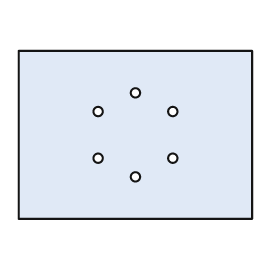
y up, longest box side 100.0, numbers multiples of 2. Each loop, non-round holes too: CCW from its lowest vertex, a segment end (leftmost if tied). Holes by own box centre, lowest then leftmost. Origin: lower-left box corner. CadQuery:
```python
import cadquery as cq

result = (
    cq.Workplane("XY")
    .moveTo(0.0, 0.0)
    .lineTo(100.0, 0.0)
    .lineTo(100.0, 72.0)
    .lineTo(0.0, 72.0)
    .close()
    .moveTo(50.0, 18.0)
    .circle(2.0)
    .moveTo(34.0, 26.0)
    .circle(2.0)
    .moveTo(66.0, 26.0)
    .circle(2.0)
    .moveTo(34.0, 46.0)
    .circle(2.0)
    .moveTo(66.0, 46.0)
    .circle(2.0)
    .moveTo(50.0, 54.0)
    .circle(2.0)
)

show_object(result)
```